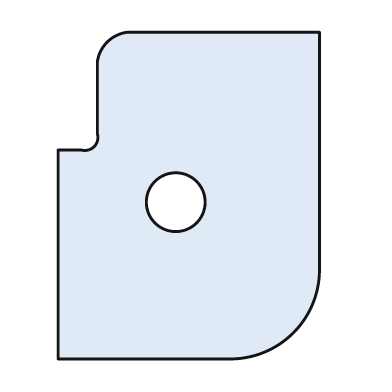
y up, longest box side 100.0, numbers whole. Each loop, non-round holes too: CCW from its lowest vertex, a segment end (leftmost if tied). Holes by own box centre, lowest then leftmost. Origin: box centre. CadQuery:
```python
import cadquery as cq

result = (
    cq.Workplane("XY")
    .moveTo(-40.0, -50.0)
    .lineTo(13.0, -50.0)
    .threePointArc((32.0, -42.0), (40.0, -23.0))
    .lineTo(40.0, 50.0)
    .lineTo(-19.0, 50.0)
    .threePointArc((-25.0, 47.0), (-28.0, 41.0))
    .lineTo(-28.0, 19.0)
    .threePointArc((-29.0, 15.0), (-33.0, 14.0))
    .lineTo(-40.0, 14.0)
    .close()
    .moveTo(-4.0, -2.0)
    .circle(9.0)
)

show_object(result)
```